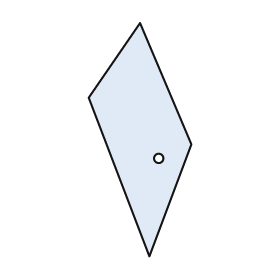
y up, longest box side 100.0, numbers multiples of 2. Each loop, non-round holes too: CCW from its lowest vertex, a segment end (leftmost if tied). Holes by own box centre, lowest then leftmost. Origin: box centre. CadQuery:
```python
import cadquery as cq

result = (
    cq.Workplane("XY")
    .moveTo(4.0, -50.0)
    .lineTo(22.0, -2.0)
    .lineTo(0.0, 50.0)
    .lineTo(-22.0, 18.0)
    .close()
    .moveTo(8.0, -8.0)
    .circle(2.0)
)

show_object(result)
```